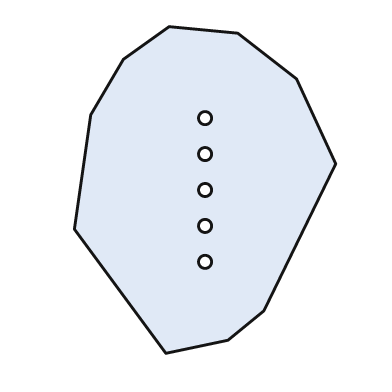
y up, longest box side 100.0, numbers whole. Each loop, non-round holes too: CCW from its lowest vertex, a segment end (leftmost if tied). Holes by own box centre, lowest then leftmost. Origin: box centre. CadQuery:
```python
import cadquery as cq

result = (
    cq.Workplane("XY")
    .moveTo(-12.0, -50.0)
    .lineTo(7.0, -46.0)
    .lineTo(18.0, -37.0)
    .lineTo(40.0, 8.0)
    .lineTo(28.0, 34.0)
    .lineTo(10.0, 48.0)
    .lineTo(-11.0, 50.0)
    .lineTo(-25.0, 40.0)
    .lineTo(-35.0, 23.0)
    .lineTo(-40.0, -12.0)
    .close()
    .moveTo(0.0, -22.0)
    .circle(2.0)
    .moveTo(0.0, -11.0)
    .circle(2.0)
    .moveTo(0.0, 0.0)
    .circle(2.0)
    .moveTo(0.0, 11.0)
    .circle(2.0)
    .moveTo(0.0, 22.0)
    .circle(2.0)
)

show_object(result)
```